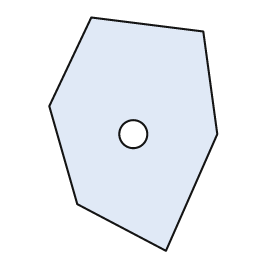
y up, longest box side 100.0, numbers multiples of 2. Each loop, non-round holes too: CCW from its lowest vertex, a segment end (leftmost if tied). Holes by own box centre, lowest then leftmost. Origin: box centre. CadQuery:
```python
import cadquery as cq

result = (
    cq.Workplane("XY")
    .moveTo(14.0, -50.0)
    .lineTo(36.0, 0.0)
    .lineTo(30.0, 44.0)
    .lineTo(-18.0, 50.0)
    .lineTo(-36.0, 12.0)
    .lineTo(-24.0, -30.0)
    .close()
    .moveTo(0.0, 0.0)
    .circle(6.0)
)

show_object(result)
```